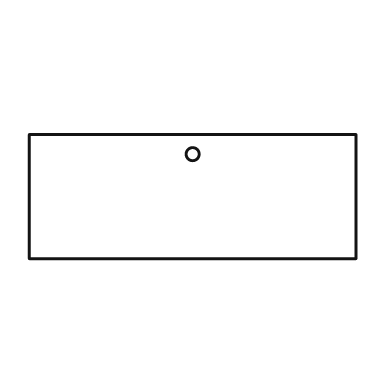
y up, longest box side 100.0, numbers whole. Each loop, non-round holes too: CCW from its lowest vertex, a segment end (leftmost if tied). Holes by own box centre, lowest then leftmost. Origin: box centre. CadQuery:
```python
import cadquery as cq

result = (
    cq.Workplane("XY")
    .moveTo(-50.0, -19.0)
    .lineTo(50.0, -19.0)
    .lineTo(50.0, 19.0)
    .lineTo(-50.0, 19.0)
    .close()
    .moveTo(0.0, 13.0)
    .circle(2.0)
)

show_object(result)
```